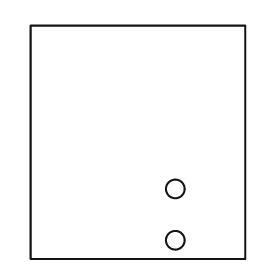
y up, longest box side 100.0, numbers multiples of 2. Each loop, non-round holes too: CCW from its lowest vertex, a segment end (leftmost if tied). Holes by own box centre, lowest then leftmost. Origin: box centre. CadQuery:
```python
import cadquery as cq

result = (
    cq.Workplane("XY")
    .moveTo(-46.0, -50.0)
    .lineTo(46.0, -50.0)
    .lineTo(46.0, 50.0)
    .lineTo(-46.0, 50.0)
    .close()
    .moveTo(16.0, -42.0)
    .circle(4.0)
    .moveTo(16.0, -20.0)
    .circle(4.0)
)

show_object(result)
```